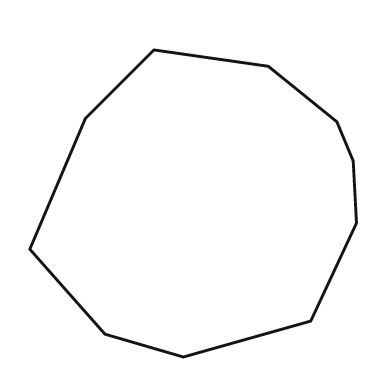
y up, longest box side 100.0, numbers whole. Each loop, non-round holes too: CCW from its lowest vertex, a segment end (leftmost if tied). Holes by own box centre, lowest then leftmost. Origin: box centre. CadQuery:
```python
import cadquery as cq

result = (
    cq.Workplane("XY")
    .moveTo(-3.0, -47.0)
    .lineTo(36.0, -36.0)
    .lineTo(50.0, -6.0)
    .lineTo(49.0, 13.0)
    .lineTo(44.0, 25.0)
    .lineTo(23.0, 42.0)
    .lineTo(-12.0, 47.0)
    .lineTo(-33.0, 26.0)
    .lineTo(-50.0, -14.0)
    .lineTo(-27.0, -40.0)
    .close()
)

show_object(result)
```